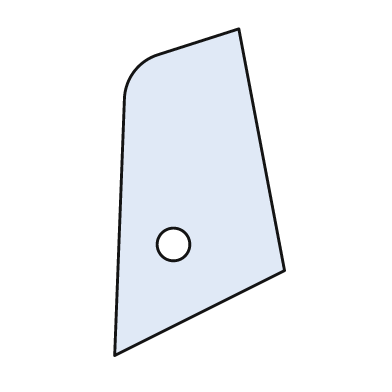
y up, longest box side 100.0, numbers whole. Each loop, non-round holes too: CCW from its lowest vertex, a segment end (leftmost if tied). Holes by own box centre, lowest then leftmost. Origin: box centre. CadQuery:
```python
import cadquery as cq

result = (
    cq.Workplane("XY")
    .moveTo(-26.0, -50.0)
    .lineTo(26.0, -24.0)
    .lineTo(12.0, 50.0)
    .lineTo(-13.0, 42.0)
    .threePointArc((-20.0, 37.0), (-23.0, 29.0))
    .close()
    .moveTo(-8.0, -16.0)
    .circle(5.0)
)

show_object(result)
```